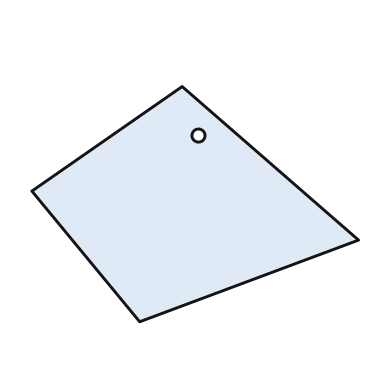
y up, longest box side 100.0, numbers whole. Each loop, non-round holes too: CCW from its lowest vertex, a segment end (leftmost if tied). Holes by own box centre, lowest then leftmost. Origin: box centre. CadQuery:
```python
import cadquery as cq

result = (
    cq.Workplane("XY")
    .moveTo(-17.0, -36.0)
    .lineTo(50.0, -11.0)
    .lineTo(-4.0, 36.0)
    .lineTo(-50.0, 4.0)
    .close()
    .moveTo(1.0, 21.0)
    .circle(2.0)
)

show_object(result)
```